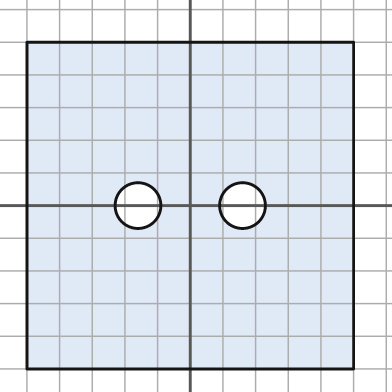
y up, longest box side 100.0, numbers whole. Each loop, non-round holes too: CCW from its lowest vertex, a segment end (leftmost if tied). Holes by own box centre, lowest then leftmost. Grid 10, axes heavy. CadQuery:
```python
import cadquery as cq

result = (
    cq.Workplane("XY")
    .moveTo(-50.0, -50.0)
    .lineTo(50.0, -50.0)
    .lineTo(50.0, 50.0)
    .lineTo(-50.0, 50.0)
    .close()
    .moveTo(-16.0, 0.0)
    .circle(7.0)
    .moveTo(16.0, 0.0)
    .circle(7.0)
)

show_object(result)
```